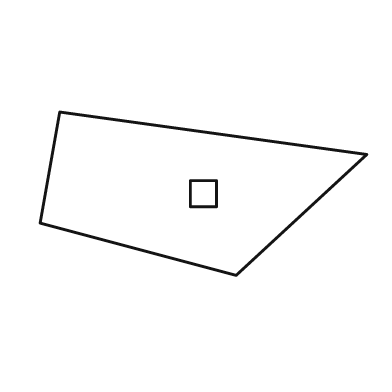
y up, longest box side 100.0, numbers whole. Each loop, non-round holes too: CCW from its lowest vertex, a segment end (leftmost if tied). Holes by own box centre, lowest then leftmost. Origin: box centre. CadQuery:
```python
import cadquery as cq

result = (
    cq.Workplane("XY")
    .moveTo(10.0, -25.0)
    .lineTo(50.0, 12.0)
    .lineTo(-44.0, 25.0)
    .lineTo(-50.0, -9.0)
    .close()
    .moveTo(-4.0, -4.0)
    .lineTo(4.0, -4.0)
    .lineTo(4.0, 4.0)
    .lineTo(-4.0, 4.0)
    .close()
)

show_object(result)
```